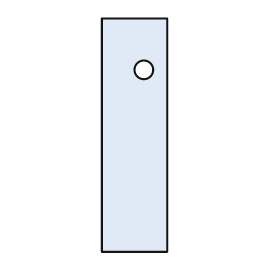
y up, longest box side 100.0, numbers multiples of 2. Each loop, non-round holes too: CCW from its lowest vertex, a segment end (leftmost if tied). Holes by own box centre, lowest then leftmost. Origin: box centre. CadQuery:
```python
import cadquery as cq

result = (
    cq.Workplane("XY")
    .moveTo(-14.0, -50.0)
    .lineTo(14.0, -50.0)
    .lineTo(14.0, 50.0)
    .lineTo(-14.0, 50.0)
    .close()
    .moveTo(4.0, 28.0)
    .circle(4.0)
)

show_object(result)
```